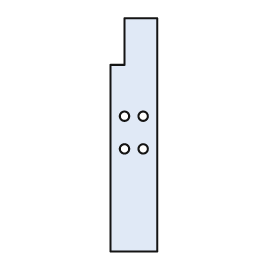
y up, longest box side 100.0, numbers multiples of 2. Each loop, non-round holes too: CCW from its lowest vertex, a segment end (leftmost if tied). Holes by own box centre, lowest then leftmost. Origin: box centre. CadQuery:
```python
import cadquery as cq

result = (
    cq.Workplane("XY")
    .moveTo(-10.0, -50.0)
    .lineTo(10.0, -50.0)
    .lineTo(10.0, 50.0)
    .lineTo(-4.0, 50.0)
    .lineTo(-4.0, 30.0)
    .lineTo(-10.0, 30.0)
    .close()
    .moveTo(-4.0, -6.0)
    .circle(2.0)
    .moveTo(4.0, -6.0)
    .circle(2.0)
    .moveTo(-4.0, 8.0)
    .circle(2.0)
    .moveTo(4.0, 8.0)
    .circle(2.0)
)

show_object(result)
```